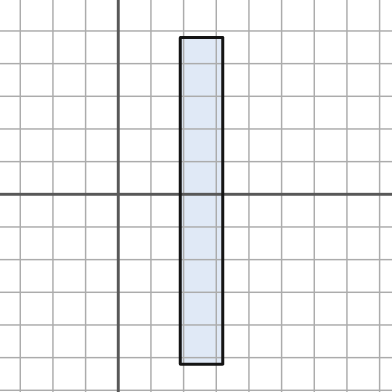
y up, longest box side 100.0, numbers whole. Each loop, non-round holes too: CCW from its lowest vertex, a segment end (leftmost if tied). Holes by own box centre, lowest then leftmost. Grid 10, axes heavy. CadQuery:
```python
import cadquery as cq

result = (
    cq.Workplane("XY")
    .moveTo(19.0, -52.0)
    .lineTo(32.0, -52.0)
    .lineTo(32.0, 48.0)
    .lineTo(19.0, 48.0)
    .close()
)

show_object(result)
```